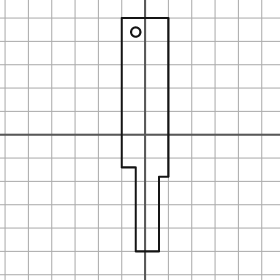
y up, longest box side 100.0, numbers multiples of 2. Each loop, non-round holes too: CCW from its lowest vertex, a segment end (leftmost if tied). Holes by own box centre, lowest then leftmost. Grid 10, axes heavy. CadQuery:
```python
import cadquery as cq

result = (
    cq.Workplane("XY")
    .moveTo(-4.0, -50.0)
    .lineTo(6.0, -50.0)
    .lineTo(6.0, -18.0)
    .lineTo(10.0, -18.0)
    .lineTo(10.0, 50.0)
    .lineTo(-10.0, 50.0)
    .lineTo(-10.0, -14.0)
    .lineTo(-4.0, -14.0)
    .close()
    .moveTo(-4.0, 44.0)
    .circle(2.0)
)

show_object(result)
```